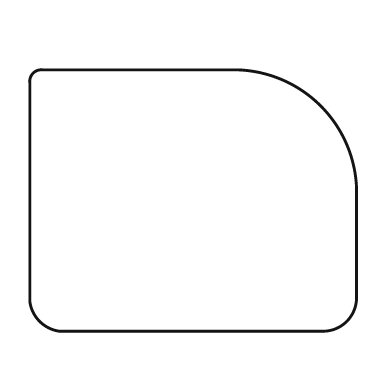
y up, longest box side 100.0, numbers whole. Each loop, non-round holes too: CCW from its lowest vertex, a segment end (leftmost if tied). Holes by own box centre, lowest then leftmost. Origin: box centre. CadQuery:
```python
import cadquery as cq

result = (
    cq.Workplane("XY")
    .moveTo(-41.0, -40.0)
    .lineTo(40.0, -40.0)
    .threePointArc((47.0, -37.0), (50.0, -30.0))
    .lineTo(50.0, 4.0)
    .threePointArc((39.0, 29.0), (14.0, 40.0))
    .lineTo(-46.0, 40.0)
    .threePointArc((-49.0, 39.0), (-50.0, 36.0))
    .lineTo(-50.0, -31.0)
    .threePointArc((-47.0, -37.0), (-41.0, -40.0))
    .close()
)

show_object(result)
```